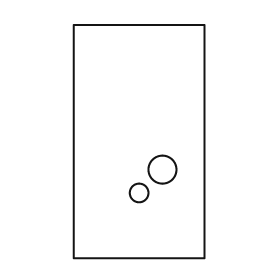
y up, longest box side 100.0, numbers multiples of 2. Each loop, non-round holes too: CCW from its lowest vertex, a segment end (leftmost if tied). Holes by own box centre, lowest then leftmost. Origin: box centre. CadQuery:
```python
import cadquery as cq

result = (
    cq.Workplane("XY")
    .moveTo(-28.0, -50.0)
    .lineTo(28.0, -50.0)
    .lineTo(28.0, 50.0)
    .lineTo(-28.0, 50.0)
    .close()
    .moveTo(0.0, -22.0)
    .circle(4.0)
    .moveTo(10.0, -12.0)
    .circle(6.0)
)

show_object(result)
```